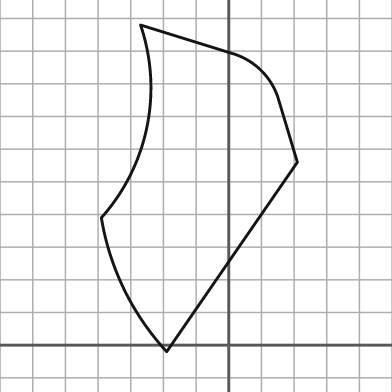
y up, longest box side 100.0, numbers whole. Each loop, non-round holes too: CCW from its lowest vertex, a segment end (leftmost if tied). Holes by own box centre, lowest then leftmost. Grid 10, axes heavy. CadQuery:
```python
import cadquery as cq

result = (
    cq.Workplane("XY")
    .moveTo(-19.0, -2.0)
    .lineTo(21.0, 56.0)
    .lineTo(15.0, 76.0)
    .threePointArc((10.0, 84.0), (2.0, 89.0))
    .lineTo(-27.0, 98.0)
    .threePointArc((-25.0, 67.0), (-39.0, 39.0))
    .threePointArc((-32.0, 17.0), (-19.0, -2.0))
    .close()
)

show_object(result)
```